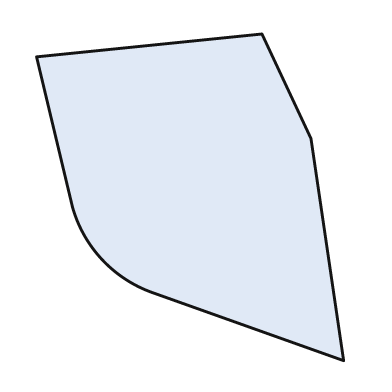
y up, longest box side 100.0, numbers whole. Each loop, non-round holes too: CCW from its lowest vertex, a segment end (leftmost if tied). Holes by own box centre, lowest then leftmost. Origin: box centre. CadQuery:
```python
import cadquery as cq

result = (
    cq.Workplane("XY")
    .moveTo(47.0, -50.0)
    .lineTo(37.0, 18.0)
    .lineTo(22.0, 50.0)
    .lineTo(-47.0, 43.0)
    .lineTo(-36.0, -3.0)
    .threePointArc((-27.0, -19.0), (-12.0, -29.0))
    .close()
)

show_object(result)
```